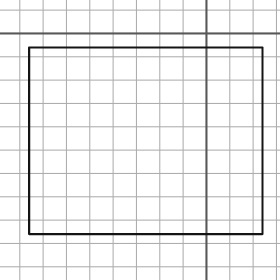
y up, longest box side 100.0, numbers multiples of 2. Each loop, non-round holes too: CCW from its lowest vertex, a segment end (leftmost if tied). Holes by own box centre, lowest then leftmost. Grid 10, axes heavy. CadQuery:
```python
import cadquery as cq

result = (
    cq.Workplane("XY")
    .moveTo(-76.0, -86.0)
    .lineTo(24.0, -86.0)
    .lineTo(24.0, -6.0)
    .lineTo(-76.0, -6.0)
    .close()
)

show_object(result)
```